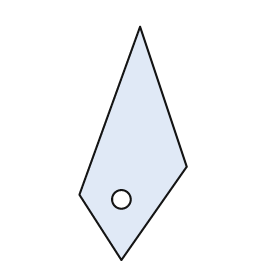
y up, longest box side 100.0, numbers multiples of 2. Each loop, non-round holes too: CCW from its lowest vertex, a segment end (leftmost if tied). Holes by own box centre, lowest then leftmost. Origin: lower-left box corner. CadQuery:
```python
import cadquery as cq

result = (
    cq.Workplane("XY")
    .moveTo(18.0, 0.0)
    .lineTo(46.0, 40.0)
    .lineTo(26.0, 100.0)
    .lineTo(0.0, 28.0)
    .close()
    .moveTo(18.0, 26.0)
    .circle(4.0)
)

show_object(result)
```